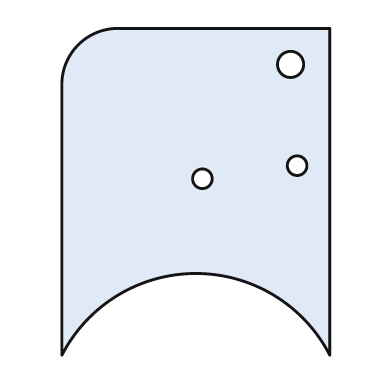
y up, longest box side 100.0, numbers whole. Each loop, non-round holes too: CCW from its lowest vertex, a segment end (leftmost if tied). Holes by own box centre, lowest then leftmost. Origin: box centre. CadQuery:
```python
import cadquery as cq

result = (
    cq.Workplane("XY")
    .moveTo(-41.0, -50.0)
    .threePointArc((0.0, -25.0), (41.0, -50.0))
    .lineTo(41.0, 50.0)
    .lineTo(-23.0, 50.0)
    .threePointArc((-36.0, 45.0), (-41.0, 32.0))
    .close()
    .moveTo(2.0, 4.0)
    .circle(3.0)
    .moveTo(31.0, 8.0)
    .circle(3.0)
    .moveTo(29.0, 39.0)
    .circle(4.0)
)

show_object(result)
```